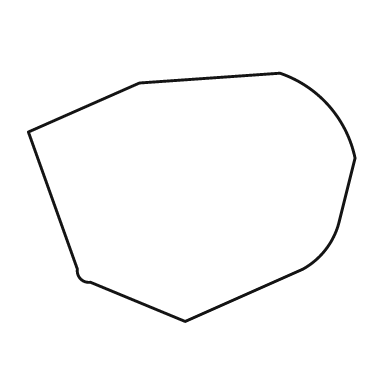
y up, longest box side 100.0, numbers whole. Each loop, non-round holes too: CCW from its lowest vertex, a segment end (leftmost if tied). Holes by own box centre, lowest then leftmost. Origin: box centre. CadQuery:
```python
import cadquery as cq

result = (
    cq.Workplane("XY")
    .moveTo(-2.0, -38.0)
    .lineTo(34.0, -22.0)
    .threePointArc((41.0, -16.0), (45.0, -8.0))
    .lineTo(50.0, 12.0)
    .threePointArc((42.0, 28.0), (27.0, 38.0))
    .lineTo(-16.0, 35.0)
    .lineTo(-50.0, 20.0)
    .lineTo(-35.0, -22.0)
    .threePointArc((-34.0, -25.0), (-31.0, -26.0))
    .close()
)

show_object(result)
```